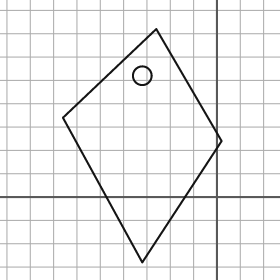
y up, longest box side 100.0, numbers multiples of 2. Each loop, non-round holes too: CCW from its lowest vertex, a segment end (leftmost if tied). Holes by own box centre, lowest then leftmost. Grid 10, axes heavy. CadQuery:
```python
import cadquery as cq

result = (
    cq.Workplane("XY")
    .moveTo(-32.0, -28.0)
    .lineTo(2.0, 24.0)
    .lineTo(-26.0, 72.0)
    .lineTo(-66.0, 34.0)
    .close()
    .moveTo(-32.0, 52.0)
    .circle(4.0)
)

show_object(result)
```